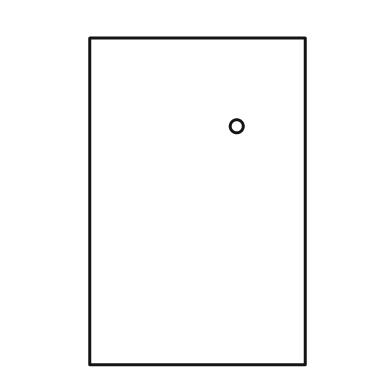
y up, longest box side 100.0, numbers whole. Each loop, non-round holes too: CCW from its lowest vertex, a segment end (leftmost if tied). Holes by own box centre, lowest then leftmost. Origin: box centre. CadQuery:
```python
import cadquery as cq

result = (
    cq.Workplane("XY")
    .moveTo(-33.0, -50.0)
    .lineTo(33.0, -50.0)
    .lineTo(33.0, 50.0)
    .lineTo(-33.0, 50.0)
    .close()
    .moveTo(12.0, 23.0)
    .circle(2.0)
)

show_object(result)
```